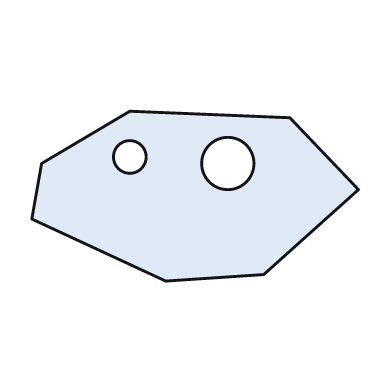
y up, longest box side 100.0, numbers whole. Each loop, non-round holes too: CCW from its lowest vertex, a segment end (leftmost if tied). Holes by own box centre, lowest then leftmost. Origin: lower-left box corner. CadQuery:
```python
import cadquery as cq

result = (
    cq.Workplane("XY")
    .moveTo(41.0, 0.0)
    .lineTo(71.0, 2.0)
    .lineTo(100.0, 28.0)
    .lineTo(79.0, 50.0)
    .lineTo(30.0, 52.0)
    .lineTo(3.0, 36.0)
    .lineTo(0.0, 19.0)
    .close()
    .moveTo(60.0, 36.0)
    .circle(8.0)
    .moveTo(30.0, 38.0)
    .circle(5.0)
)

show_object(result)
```